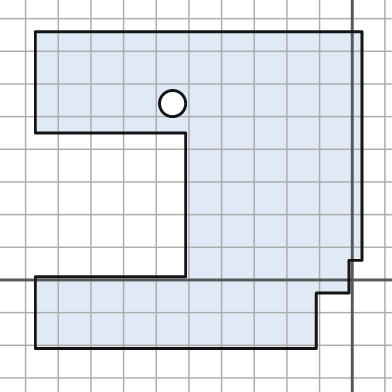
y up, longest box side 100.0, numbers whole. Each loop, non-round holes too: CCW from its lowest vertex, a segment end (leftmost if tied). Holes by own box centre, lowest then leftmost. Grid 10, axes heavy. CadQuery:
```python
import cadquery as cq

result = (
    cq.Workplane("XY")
    .moveTo(-97.0, -21.0)
    .lineTo(-11.0, -21.0)
    .lineTo(-11.0, -4.0)
    .lineTo(-1.0, -4.0)
    .lineTo(-1.0, 6.0)
    .lineTo(3.0, 6.0)
    .lineTo(3.0, 76.0)
    .lineTo(-97.0, 76.0)
    .lineTo(-97.0, 45.0)
    .lineTo(-51.0, 45.0)
    .lineTo(-51.0, 1.0)
    .lineTo(-97.0, 1.0)
    .close()
    .moveTo(-55.0, 54.0)
    .circle(4.0)
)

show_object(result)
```